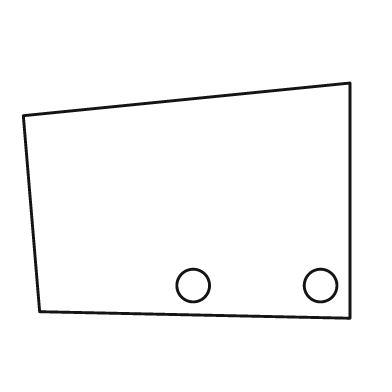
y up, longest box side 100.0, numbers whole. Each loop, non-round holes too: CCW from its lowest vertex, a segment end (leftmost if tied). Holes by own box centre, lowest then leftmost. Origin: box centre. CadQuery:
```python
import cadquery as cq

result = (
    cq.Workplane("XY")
    .moveTo(50.0, -36.0)
    .lineTo(50.0, 36.0)
    .lineTo(-50.0, 26.0)
    .lineTo(-45.0, -34.0)
    .close()
    .moveTo(2.0, -26.0)
    .circle(5.0)
    .moveTo(41.0, -26.0)
    .circle(5.0)
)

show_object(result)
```